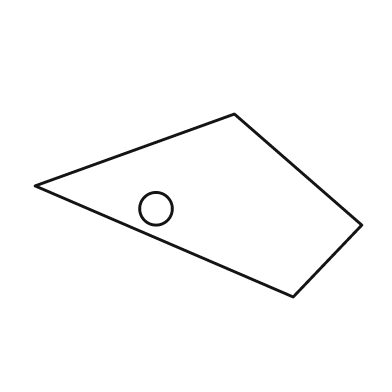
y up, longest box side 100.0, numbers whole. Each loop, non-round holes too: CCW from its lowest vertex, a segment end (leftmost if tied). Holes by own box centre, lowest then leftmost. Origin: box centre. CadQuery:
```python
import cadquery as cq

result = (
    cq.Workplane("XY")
    .moveTo(29.0, -28.0)
    .lineTo(50.0, -6.0)
    .lineTo(11.0, 28.0)
    .lineTo(-50.0, 6.0)
    .close()
    .moveTo(-13.0, -1.0)
    .circle(5.0)
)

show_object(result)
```